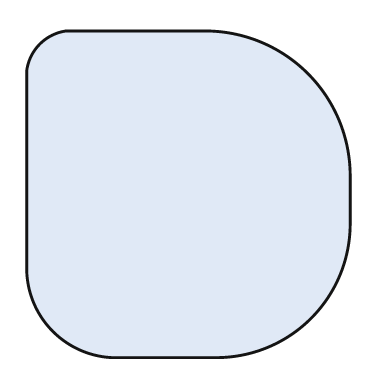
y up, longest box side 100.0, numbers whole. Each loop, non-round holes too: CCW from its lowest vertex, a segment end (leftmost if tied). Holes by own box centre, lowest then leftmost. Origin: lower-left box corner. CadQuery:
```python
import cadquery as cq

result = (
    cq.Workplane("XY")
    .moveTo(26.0, 0.0)
    .lineTo(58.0, 0.0)
    .threePointArc((87.0, 12.0), (99.0, 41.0))
    .lineTo(99.0, 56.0)
    .threePointArc((86.0, 87.0), (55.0, 100.0))
    .lineTo(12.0, 100.0)
    .threePointArc((4.0, 96.0), (0.0, 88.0))
    .lineTo(0.0, 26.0)
    .threePointArc((8.0, 8.0), (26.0, 0.0))
    .close()
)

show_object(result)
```